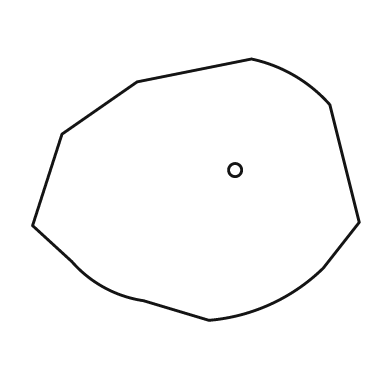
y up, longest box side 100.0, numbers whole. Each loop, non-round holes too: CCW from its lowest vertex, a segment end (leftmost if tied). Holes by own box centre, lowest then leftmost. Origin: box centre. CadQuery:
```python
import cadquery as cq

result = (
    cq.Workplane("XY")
    .moveTo(4.0, -40.0)
    .threePointArc((23.0, -35.0), (39.0, -24.0))
    .lineTo(50.0, -10.0)
    .lineTo(41.0, 26.0)
    .threePointArc((30.0, 35.0), (17.0, 40.0))
    .lineTo(-18.0, 33.0)
    .lineTo(-41.0, 17.0)
    .lineTo(-50.0, -11.0)
    .lineTo(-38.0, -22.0)
    .threePointArc((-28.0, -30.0), (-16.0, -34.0))
    .close()
    .moveTo(12.0, 6.0)
    .circle(2.0)
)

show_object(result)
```